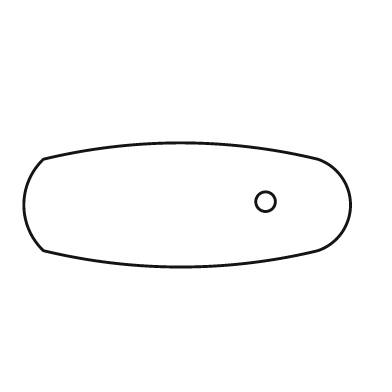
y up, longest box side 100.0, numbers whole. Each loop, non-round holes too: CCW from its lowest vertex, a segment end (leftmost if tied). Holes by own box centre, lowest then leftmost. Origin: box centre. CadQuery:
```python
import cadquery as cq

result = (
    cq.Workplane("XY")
    .moveTo(-44.0, -14.0)
    .threePointArc((-2.0, -19.0), (40.0, -14.0))
    .threePointArc((50.0, 0.0), (40.0, 14.0))
    .threePointArc((-2.0, 19.0), (-44.0, 14.0))
    .threePointArc((-50.0, 0.0), (-44.0, -14.0))
    .close()
    .moveTo(24.0, 1.0)
    .circle(3.0)
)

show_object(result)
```